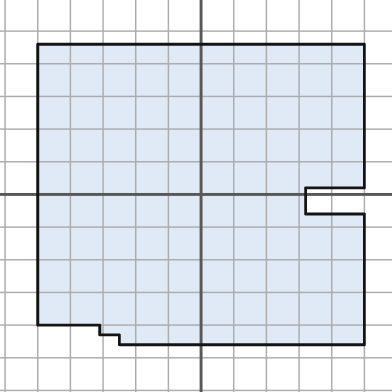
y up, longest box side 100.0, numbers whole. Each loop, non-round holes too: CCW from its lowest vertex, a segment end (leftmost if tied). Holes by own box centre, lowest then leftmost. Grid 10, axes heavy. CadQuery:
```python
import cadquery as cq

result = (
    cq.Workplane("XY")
    .moveTo(-25.0, -46.0)
    .lineTo(50.0, -46.0)
    .lineTo(50.0, -6.0)
    .lineTo(32.0, -6.0)
    .lineTo(32.0, 2.0)
    .lineTo(50.0, 2.0)
    .lineTo(50.0, 46.0)
    .lineTo(-50.0, 46.0)
    .lineTo(-50.0, -40.0)
    .lineTo(-31.0, -40.0)
    .lineTo(-31.0, -43.0)
    .lineTo(-25.0, -43.0)
    .close()
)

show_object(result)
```